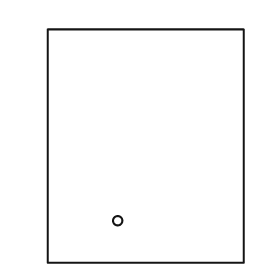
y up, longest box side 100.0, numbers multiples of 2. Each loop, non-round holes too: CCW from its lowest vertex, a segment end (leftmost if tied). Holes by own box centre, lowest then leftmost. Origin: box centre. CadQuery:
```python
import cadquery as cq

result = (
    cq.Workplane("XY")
    .moveTo(-42.0, -50.0)
    .lineTo(42.0, -50.0)
    .lineTo(42.0, 50.0)
    .lineTo(-42.0, 50.0)
    .close()
    .moveTo(-12.0, -32.0)
    .circle(2.0)
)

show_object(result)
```